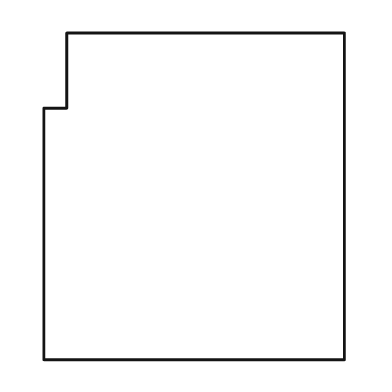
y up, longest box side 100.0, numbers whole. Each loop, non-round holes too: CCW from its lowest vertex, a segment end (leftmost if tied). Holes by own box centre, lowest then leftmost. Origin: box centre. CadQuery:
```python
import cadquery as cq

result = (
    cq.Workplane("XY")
    .moveTo(-46.0, -50.0)
    .lineTo(46.0, -50.0)
    .lineTo(46.0, 50.0)
    .lineTo(-39.0, 50.0)
    .lineTo(-39.0, 27.0)
    .lineTo(-46.0, 27.0)
    .close()
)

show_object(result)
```